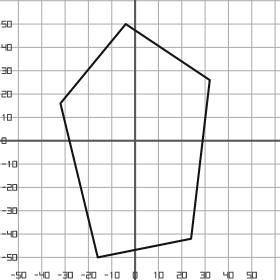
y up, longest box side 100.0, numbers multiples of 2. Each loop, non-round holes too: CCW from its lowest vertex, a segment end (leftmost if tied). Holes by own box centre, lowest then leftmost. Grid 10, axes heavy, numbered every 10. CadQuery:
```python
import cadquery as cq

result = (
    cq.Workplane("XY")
    .moveTo(-16.0, -50.0)
    .lineTo(24.0, -42.0)
    .lineTo(32.0, 26.0)
    .lineTo(-4.0, 50.0)
    .lineTo(-32.0, 16.0)
    .close()
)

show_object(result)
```